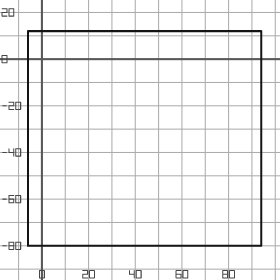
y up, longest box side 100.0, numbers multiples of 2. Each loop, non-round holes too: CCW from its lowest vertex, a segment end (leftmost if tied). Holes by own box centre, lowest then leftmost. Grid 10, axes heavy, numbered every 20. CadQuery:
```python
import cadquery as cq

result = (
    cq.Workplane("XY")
    .moveTo(-6.0, -80.0)
    .lineTo(94.0, -80.0)
    .lineTo(94.0, 12.0)
    .lineTo(-6.0, 12.0)
    .close()
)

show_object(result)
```